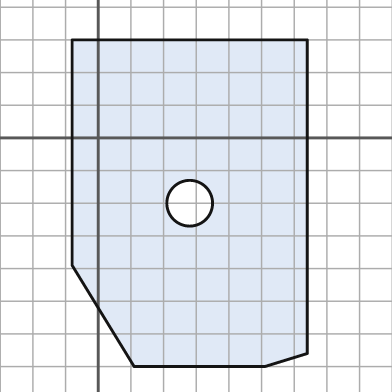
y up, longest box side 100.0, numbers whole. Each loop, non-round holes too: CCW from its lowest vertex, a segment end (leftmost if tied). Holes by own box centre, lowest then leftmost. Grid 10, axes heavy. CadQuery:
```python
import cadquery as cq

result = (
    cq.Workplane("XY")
    .moveTo(11.0, -70.0)
    .lineTo(51.0, -70.0)
    .lineTo(64.0, -66.0)
    .lineTo(64.0, 30.0)
    .lineTo(-8.0, 30.0)
    .lineTo(-8.0, -39.0)
    .close()
    .moveTo(28.0, -20.0)
    .circle(7.0)
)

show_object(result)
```